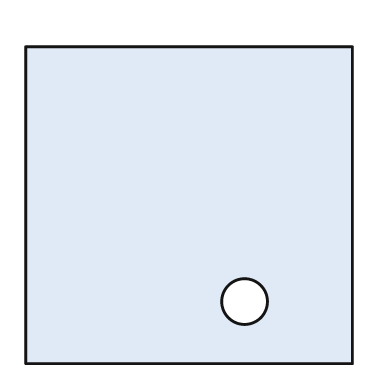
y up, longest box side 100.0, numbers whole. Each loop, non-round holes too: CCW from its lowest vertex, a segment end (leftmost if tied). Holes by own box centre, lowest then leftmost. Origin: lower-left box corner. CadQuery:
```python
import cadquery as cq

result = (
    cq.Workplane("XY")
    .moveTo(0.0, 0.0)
    .lineTo(100.0, 0.0)
    .lineTo(100.0, 97.0)
    .lineTo(0.0, 97.0)
    .close()
    .moveTo(67.0, 19.0)
    .circle(7.0)
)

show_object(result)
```